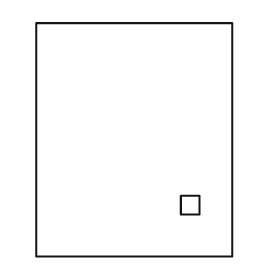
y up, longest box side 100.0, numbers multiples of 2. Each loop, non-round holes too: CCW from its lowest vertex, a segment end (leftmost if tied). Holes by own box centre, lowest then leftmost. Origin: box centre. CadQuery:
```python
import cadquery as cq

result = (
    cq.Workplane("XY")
    .moveTo(-42.0, -50.0)
    .lineTo(42.0, -50.0)
    .lineTo(42.0, 50.0)
    .lineTo(-42.0, 50.0)
    .close()
    .moveTo(20.0, -32.0)
    .lineTo(28.0, -32.0)
    .lineTo(28.0, -24.0)
    .lineTo(20.0, -24.0)
    .close()
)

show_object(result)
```